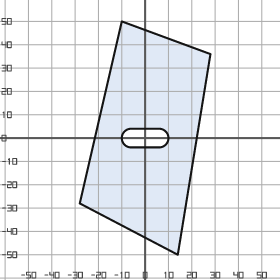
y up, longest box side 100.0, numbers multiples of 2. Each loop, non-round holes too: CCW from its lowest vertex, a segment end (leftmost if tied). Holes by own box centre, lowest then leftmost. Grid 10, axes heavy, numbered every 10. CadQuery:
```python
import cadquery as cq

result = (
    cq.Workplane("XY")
    .moveTo(14.0, -50.0)
    .lineTo(28.0, 36.0)
    .lineTo(-10.0, 50.0)
    .lineTo(-28.0, -28.0)
    .close()
    .moveTo(-6.0, -4.0)
    .lineTo(6.0, -4.0)
    .threePointArc((10.0, 0.0), (6.0, 4.0))
    .lineTo(-6.0, 4.0)
    .threePointArc((-10.0, 0.0), (-6.0, -4.0))
    .close()
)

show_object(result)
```